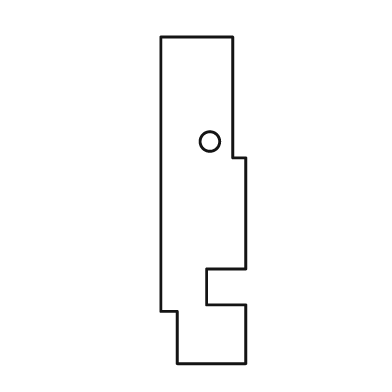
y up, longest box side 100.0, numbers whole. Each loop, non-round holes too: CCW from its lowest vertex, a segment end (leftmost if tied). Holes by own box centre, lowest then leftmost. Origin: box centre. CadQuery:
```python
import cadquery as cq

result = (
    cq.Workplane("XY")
    .moveTo(-8.0, -50.0)
    .lineTo(13.0, -50.0)
    .lineTo(13.0, -32.0)
    .lineTo(1.0, -32.0)
    .lineTo(1.0, -21.0)
    .lineTo(13.0, -21.0)
    .lineTo(13.0, 13.0)
    .lineTo(9.0, 13.0)
    .lineTo(9.0, 50.0)
    .lineTo(-13.0, 50.0)
    .lineTo(-13.0, -34.0)
    .lineTo(-8.0, -34.0)
    .close()
    .moveTo(2.0, 18.0)
    .circle(3.0)
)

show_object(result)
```